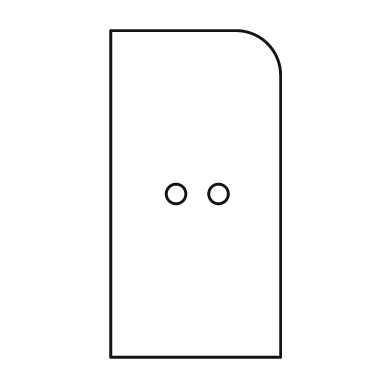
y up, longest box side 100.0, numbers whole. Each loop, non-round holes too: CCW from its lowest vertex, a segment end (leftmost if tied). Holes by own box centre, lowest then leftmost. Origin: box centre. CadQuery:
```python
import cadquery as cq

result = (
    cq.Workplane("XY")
    .moveTo(-26.0, -50.0)
    .lineTo(26.0, -50.0)
    .lineTo(26.0, 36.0)
    .threePointArc((22.0, 46.0), (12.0, 50.0))
    .lineTo(-26.0, 50.0)
    .close()
    .moveTo(-6.0, 0.0)
    .circle(3.0)
    .moveTo(7.0, 0.0)
    .circle(3.0)
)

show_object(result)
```